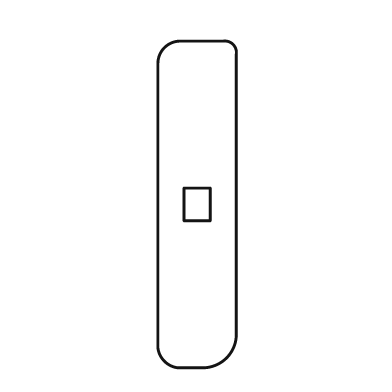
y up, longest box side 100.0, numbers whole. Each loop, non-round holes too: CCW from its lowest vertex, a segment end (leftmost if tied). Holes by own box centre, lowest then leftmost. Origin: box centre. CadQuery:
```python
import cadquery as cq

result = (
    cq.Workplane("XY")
    .moveTo(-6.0, -50.0)
    .lineTo(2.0, -50.0)
    .threePointArc((9.0, -47.0), (12.0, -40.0))
    .lineTo(12.0, 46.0)
    .threePointArc((11.0, 49.0), (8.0, 50.0))
    .lineTo(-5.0, 50.0)
    .threePointArc((-10.0, 48.0), (-12.0, 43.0))
    .lineTo(-12.0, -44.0)
    .threePointArc((-10.0, -48.0), (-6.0, -50.0))
    .close()
    .moveTo(-4.0, -5.0)
    .lineTo(4.0, -5.0)
    .lineTo(4.0, 5.0)
    .lineTo(-4.0, 5.0)
    .close()
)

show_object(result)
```